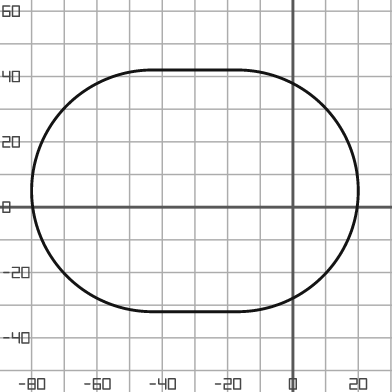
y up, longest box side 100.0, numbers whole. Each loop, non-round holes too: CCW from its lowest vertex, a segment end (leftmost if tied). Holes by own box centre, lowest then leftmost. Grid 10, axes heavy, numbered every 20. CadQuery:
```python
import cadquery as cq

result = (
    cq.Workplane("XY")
    .moveTo(-43.0, -32.0)
    .lineTo(-17.0, -32.0)
    .threePointArc((20.0, 5.0), (-17.0, 42.0))
    .lineTo(-43.0, 42.0)
    .threePointArc((-80.0, 5.0), (-43.0, -32.0))
    .close()
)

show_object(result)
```